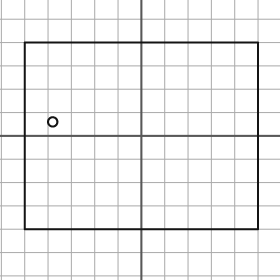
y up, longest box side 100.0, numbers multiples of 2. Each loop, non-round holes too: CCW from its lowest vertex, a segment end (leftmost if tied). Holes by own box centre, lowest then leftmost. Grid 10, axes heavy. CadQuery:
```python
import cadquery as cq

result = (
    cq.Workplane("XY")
    .moveTo(-50.0, -40.0)
    .lineTo(50.0, -40.0)
    .lineTo(50.0, 40.0)
    .lineTo(-50.0, 40.0)
    .close()
    .moveTo(-38.0, 6.0)
    .circle(2.0)
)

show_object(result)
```